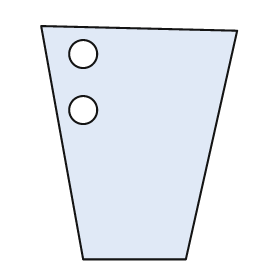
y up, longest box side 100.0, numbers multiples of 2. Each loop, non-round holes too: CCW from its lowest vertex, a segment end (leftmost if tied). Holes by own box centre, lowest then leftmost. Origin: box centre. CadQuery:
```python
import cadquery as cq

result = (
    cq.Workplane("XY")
    .moveTo(-24.0, -50.0)
    .lineTo(20.0, -50.0)
    .lineTo(42.0, 48.0)
    .lineTo(-42.0, 50.0)
    .close()
    .moveTo(-24.0, 14.0)
    .circle(6.0)
    .moveTo(-24.0, 38.0)
    .circle(6.0)
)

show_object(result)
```